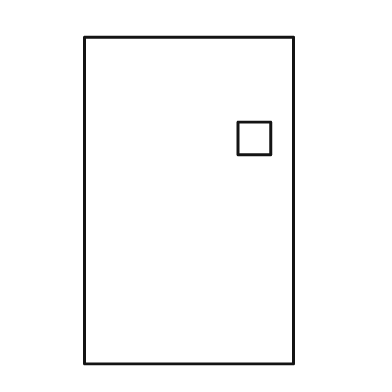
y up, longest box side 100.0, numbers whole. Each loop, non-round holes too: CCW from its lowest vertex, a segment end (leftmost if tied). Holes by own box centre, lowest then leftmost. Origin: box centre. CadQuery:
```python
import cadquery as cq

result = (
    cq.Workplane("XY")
    .moveTo(-32.0, -50.0)
    .lineTo(32.0, -50.0)
    .lineTo(32.0, 50.0)
    .lineTo(-32.0, 50.0)
    .close()
    .moveTo(15.0, 14.0)
    .lineTo(25.0, 14.0)
    .lineTo(25.0, 24.0)
    .lineTo(15.0, 24.0)
    .close()
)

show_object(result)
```